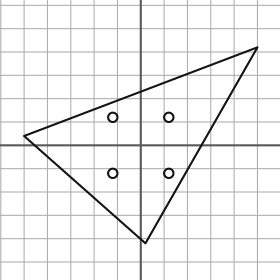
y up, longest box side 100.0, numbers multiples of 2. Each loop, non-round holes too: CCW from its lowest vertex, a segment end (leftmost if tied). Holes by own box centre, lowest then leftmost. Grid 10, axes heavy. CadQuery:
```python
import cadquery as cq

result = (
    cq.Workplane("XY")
    .moveTo(2.0, -42.0)
    .lineTo(50.0, 42.0)
    .lineTo(-50.0, 4.0)
    .close()
    .moveTo(-12.0, -12.0)
    .circle(2.0)
    .moveTo(12.0, -12.0)
    .circle(2.0)
    .moveTo(-12.0, 12.0)
    .circle(2.0)
    .moveTo(12.0, 12.0)
    .circle(2.0)
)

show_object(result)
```